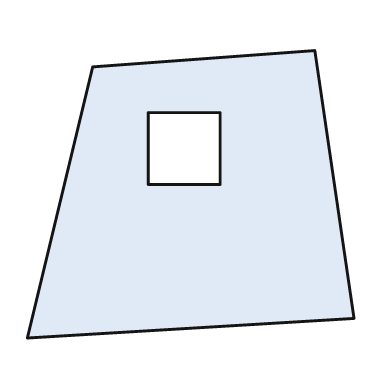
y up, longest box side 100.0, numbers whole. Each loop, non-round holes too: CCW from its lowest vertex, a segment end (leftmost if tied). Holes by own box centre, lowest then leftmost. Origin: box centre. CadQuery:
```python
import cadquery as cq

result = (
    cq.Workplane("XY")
    .moveTo(-50.0, -44.0)
    .lineTo(50.0, -38.0)
    .lineTo(38.0, 44.0)
    .lineTo(-30.0, 39.0)
    .close()
    .moveTo(-13.0, 3.0)
    .lineTo(9.0, 3.0)
    .lineTo(9.0, 25.0)
    .lineTo(-13.0, 25.0)
    .close()
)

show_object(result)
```